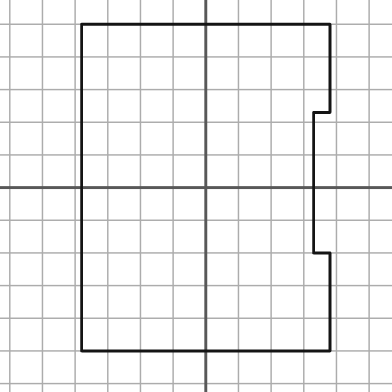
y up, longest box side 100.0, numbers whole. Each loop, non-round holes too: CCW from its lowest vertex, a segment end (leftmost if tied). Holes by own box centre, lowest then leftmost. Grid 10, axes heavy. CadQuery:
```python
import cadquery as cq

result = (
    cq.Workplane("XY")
    .moveTo(-38.0, -50.0)
    .lineTo(38.0, -50.0)
    .lineTo(38.0, -20.0)
    .lineTo(33.0, -20.0)
    .lineTo(33.0, 23.0)
    .lineTo(38.0, 23.0)
    .lineTo(38.0, 50.0)
    .lineTo(-38.0, 50.0)
    .close()
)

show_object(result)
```